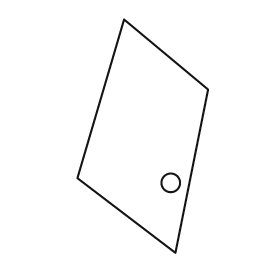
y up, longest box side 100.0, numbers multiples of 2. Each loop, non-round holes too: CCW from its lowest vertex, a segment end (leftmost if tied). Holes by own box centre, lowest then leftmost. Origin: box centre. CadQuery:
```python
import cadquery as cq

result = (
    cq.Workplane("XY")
    .moveTo(14.0, -50.0)
    .lineTo(28.0, 20.0)
    .lineTo(-8.0, 50.0)
    .lineTo(-28.0, -18.0)
    .close()
    .moveTo(12.0, -20.0)
    .circle(4.0)
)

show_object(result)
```